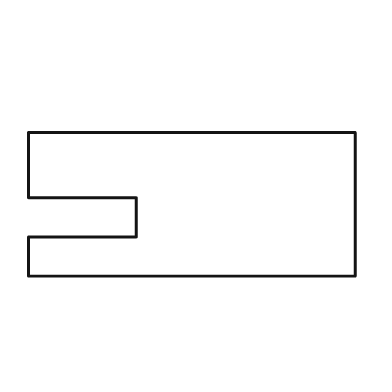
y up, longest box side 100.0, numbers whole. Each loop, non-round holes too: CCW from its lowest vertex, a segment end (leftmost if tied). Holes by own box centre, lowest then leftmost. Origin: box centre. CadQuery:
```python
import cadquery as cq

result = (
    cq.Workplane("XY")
    .moveTo(-50.0, -22.0)
    .lineTo(50.0, -22.0)
    .lineTo(50.0, 22.0)
    .lineTo(-50.0, 22.0)
    .lineTo(-50.0, 2.0)
    .lineTo(-17.0, 2.0)
    .lineTo(-17.0, -10.0)
    .lineTo(-50.0, -10.0)
    .close()
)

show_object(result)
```